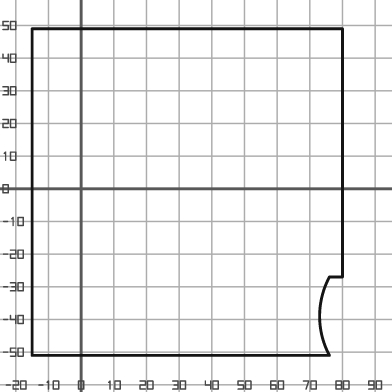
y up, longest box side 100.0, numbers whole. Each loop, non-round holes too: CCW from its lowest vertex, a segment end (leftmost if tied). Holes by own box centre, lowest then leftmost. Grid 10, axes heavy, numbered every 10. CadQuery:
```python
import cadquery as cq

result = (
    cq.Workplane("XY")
    .moveTo(-15.0, -51.0)
    .lineTo(76.0, -51.0)
    .threePointArc((73.0, -39.0), (76.0, -27.0))
    .lineTo(80.0, -27.0)
    .lineTo(80.0, 49.0)
    .lineTo(-15.0, 49.0)
    .close()
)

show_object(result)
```